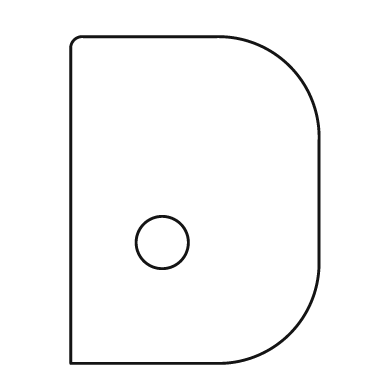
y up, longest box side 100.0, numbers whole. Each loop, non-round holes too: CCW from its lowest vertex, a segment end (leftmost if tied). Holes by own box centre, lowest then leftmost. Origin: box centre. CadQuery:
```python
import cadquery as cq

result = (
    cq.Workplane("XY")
    .moveTo(-38.0, -50.0)
    .lineTo(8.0, -50.0)
    .threePointArc((29.0, -41.0), (38.0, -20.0))
    .lineTo(38.0, 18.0)
    .threePointArc((29.0, 41.0), (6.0, 50.0))
    .lineTo(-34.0, 50.0)
    .threePointArc((-37.0, 49.0), (-38.0, 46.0))
    .close()
    .moveTo(-10.0, -13.0)
    .circle(8.0)
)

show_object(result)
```